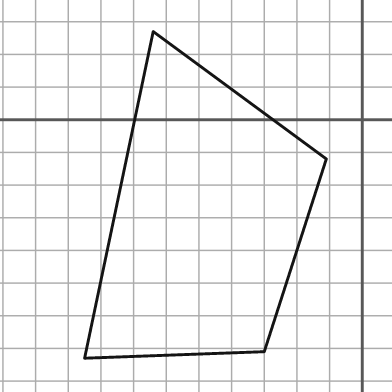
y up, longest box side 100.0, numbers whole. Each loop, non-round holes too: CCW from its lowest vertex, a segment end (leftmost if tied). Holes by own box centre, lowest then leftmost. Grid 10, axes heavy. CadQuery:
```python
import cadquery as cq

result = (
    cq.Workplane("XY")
    .moveTo(-85.0, -73.0)
    .lineTo(-30.0, -71.0)
    .lineTo(-11.0, -12.0)
    .lineTo(-64.0, 27.0)
    .close()
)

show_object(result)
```